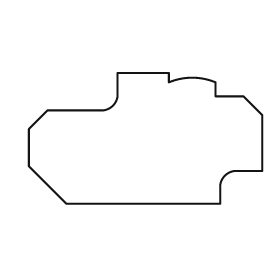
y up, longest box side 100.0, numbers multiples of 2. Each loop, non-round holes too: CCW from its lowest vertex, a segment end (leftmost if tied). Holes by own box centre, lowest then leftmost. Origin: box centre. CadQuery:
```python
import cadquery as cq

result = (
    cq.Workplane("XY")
    .moveTo(-34.0, -28.0)
    .lineTo(32.0, -28.0)
    .lineTo(32.0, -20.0)
    .threePointArc((34.0, -16.0), (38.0, -14.0))
    .lineTo(50.0, -14.0)
    .lineTo(50.0, 10.0)
    .lineTo(42.0, 18.0)
    .lineTo(30.0, 18.0)
    .lineTo(30.0, 24.0)
    .threePointArc((20.0, 26.0), (10.0, 24.0))
    .lineTo(10.0, 28.0)
    .lineTo(-12.0, 28.0)
    .lineTo(-12.0, 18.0)
    .threePointArc((-14.0, 14.0), (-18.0, 12.0))
    .lineTo(-42.0, 12.0)
    .lineTo(-50.0, 4.0)
    .lineTo(-50.0, -12.0)
    .close()
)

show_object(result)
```